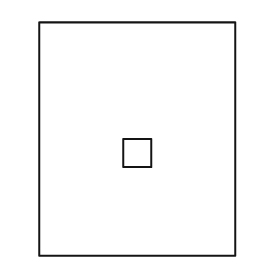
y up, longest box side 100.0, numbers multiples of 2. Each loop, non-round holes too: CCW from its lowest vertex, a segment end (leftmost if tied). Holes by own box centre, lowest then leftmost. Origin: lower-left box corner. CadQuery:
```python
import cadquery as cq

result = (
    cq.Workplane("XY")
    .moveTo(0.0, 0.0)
    .lineTo(84.0, 0.0)
    .lineTo(84.0, 100.0)
    .lineTo(0.0, 100.0)
    .close()
    .moveTo(36.0, 38.0)
    .lineTo(48.0, 38.0)
    .lineTo(48.0, 50.0)
    .lineTo(36.0, 50.0)
    .close()
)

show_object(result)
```